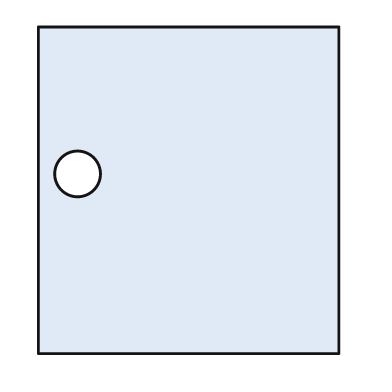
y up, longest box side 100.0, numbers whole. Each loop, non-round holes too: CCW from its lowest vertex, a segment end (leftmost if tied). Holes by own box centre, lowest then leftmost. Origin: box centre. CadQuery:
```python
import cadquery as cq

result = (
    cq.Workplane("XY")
    .moveTo(-46.0, -50.0)
    .lineTo(46.0, -50.0)
    .lineTo(46.0, 50.0)
    .lineTo(-46.0, 50.0)
    .close()
    .moveTo(-34.0, 5.0)
    .circle(7.0)
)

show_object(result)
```